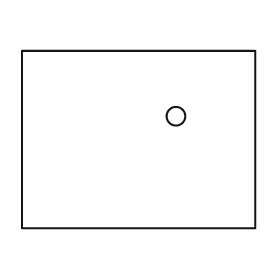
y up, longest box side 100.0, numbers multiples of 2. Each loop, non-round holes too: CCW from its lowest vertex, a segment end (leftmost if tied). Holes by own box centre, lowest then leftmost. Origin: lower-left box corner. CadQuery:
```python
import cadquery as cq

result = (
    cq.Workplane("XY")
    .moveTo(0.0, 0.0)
    .lineTo(100.0, 0.0)
    .lineTo(100.0, 76.0)
    .lineTo(0.0, 76.0)
    .close()
    .moveTo(66.0, 48.0)
    .circle(4.0)
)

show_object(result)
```